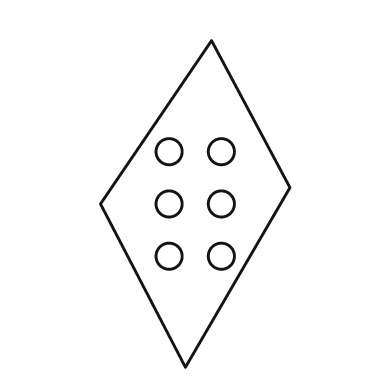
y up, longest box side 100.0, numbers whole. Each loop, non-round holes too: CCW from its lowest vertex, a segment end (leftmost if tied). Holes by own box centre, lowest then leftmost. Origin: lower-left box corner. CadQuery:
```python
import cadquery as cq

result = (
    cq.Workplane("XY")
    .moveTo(26.0, 0.0)
    .lineTo(58.0, 55.0)
    .lineTo(34.0, 100.0)
    .lineTo(0.0, 50.0)
    .close()
    .moveTo(21.0, 34.0)
    .circle(4.0)
    .moveTo(37.0, 34.0)
    .circle(4.0)
    .moveTo(21.0, 50.0)
    .circle(4.0)
    .moveTo(37.0, 50.0)
    .circle(4.0)
    .moveTo(21.0, 66.0)
    .circle(4.0)
    .moveTo(37.0, 66.0)
    .circle(4.0)
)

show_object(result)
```